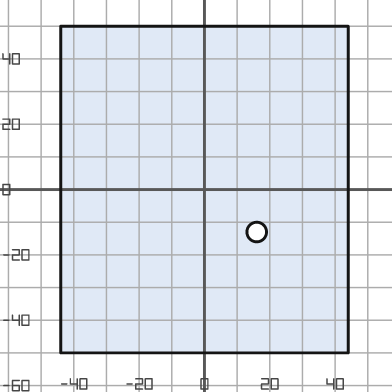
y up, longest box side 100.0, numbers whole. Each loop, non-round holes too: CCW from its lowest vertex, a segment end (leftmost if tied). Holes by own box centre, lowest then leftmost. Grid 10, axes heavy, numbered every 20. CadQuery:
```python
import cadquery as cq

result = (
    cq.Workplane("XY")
    .moveTo(-44.0, -50.0)
    .lineTo(44.0, -50.0)
    .lineTo(44.0, 50.0)
    .lineTo(-44.0, 50.0)
    .close()
    .moveTo(16.0, -13.0)
    .circle(3.0)
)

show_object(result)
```